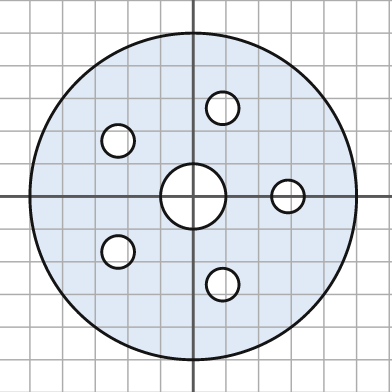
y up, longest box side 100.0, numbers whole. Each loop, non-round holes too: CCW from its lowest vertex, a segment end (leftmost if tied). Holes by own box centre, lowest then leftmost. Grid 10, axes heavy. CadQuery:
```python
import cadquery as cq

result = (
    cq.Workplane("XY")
    .moveTo(0.0, 0.0)
    .circle(50.0)
    .moveTo(9.0, -27.0)
    .circle(5.0)
    .moveTo(-23.0, -17.0)
    .circle(5.0)
    .moveTo(0.0, 0.0)
    .circle(10.0)
    .moveTo(29.0, 0.0)
    .circle(5.0)
    .moveTo(-23.0, 17.0)
    .circle(5.0)
    .moveTo(9.0, 27.0)
    .circle(5.0)
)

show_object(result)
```